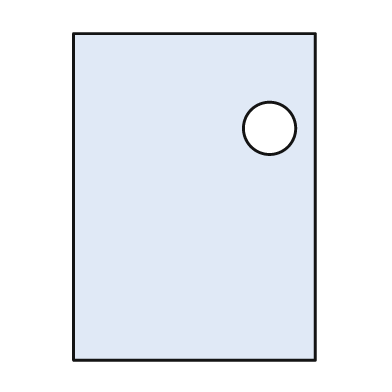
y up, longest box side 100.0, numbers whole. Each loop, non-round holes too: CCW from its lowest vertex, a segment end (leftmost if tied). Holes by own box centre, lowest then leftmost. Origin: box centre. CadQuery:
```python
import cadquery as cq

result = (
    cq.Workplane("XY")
    .moveTo(-37.0, -50.0)
    .lineTo(37.0, -50.0)
    .lineTo(37.0, 50.0)
    .lineTo(-37.0, 50.0)
    .close()
    .moveTo(23.0, 21.0)
    .circle(8.0)
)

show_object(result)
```